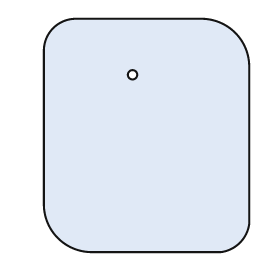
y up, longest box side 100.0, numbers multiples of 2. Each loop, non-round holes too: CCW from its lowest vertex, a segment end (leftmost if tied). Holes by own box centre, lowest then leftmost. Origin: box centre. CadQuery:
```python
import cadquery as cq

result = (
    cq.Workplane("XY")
    .moveTo(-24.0, -50.0)
    .lineTo(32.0, -50.0)
    .threePointArc((40.0, -46.0), (44.0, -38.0))
    .lineTo(44.0, 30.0)
    .threePointArc((38.0, 44.0), (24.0, 50.0))
    .lineTo(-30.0, 50.0)
    .threePointArc((-40.0, 46.0), (-44.0, 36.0))
    .lineTo(-44.0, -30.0)
    .threePointArc((-38.0, -44.0), (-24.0, -50.0))
    .close()
    .moveTo(-6.0, 26.0)
    .circle(2.0)
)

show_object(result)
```